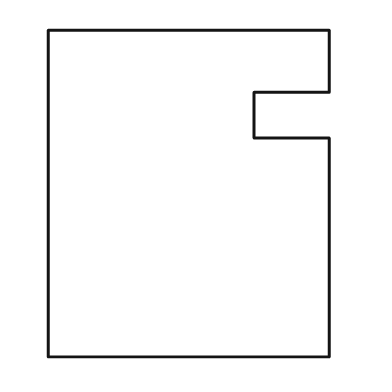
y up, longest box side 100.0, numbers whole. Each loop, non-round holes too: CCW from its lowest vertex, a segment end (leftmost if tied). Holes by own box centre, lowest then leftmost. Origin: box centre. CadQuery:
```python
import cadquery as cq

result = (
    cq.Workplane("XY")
    .moveTo(-43.0, -50.0)
    .lineTo(43.0, -50.0)
    .lineTo(43.0, 17.0)
    .lineTo(20.0, 17.0)
    .lineTo(20.0, 31.0)
    .lineTo(43.0, 31.0)
    .lineTo(43.0, 50.0)
    .lineTo(-43.0, 50.0)
    .close()
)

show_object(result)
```